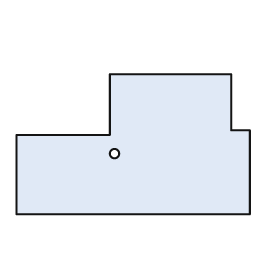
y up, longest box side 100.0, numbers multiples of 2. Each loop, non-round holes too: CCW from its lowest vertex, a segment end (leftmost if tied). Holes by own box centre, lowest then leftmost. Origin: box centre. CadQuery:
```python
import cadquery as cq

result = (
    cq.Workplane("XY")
    .moveTo(-50.0, -30.0)
    .lineTo(50.0, -30.0)
    .lineTo(50.0, 6.0)
    .lineTo(42.0, 6.0)
    .lineTo(42.0, 30.0)
    .lineTo(-10.0, 30.0)
    .lineTo(-10.0, 4.0)
    .lineTo(-50.0, 4.0)
    .close()
    .moveTo(-8.0, -4.0)
    .circle(2.0)
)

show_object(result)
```